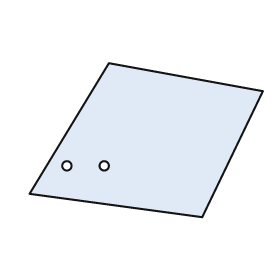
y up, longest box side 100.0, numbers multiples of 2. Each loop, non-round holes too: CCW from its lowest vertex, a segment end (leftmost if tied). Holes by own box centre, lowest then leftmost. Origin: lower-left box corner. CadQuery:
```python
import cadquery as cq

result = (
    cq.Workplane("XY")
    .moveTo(74.0, 0.0)
    .lineTo(100.0, 54.0)
    .lineTo(34.0, 66.0)
    .lineTo(0.0, 10.0)
    .close()
    .moveTo(16.0, 22.0)
    .circle(2.0)
    .moveTo(32.0, 22.0)
    .circle(2.0)
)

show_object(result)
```